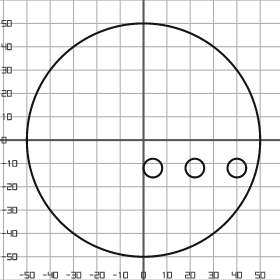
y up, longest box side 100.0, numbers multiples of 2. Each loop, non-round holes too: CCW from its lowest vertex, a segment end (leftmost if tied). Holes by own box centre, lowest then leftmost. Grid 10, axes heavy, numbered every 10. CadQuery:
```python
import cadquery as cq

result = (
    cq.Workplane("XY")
    .moveTo(0.0, 0.0)
    .circle(50.0)
    .moveTo(4.0, -12.0)
    .circle(4.0)
    .moveTo(22.0, -12.0)
    .circle(4.0)
    .moveTo(40.0, -12.0)
    .circle(4.0)
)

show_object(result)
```